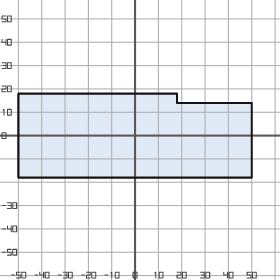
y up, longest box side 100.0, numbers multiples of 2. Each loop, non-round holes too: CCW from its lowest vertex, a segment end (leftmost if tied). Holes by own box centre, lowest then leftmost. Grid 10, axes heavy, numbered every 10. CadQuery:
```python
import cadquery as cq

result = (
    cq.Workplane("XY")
    .moveTo(-50.0, -18.0)
    .lineTo(50.0, -18.0)
    .lineTo(50.0, 14.0)
    .lineTo(18.0, 14.0)
    .lineTo(18.0, 18.0)
    .lineTo(-50.0, 18.0)
    .close()
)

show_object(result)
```